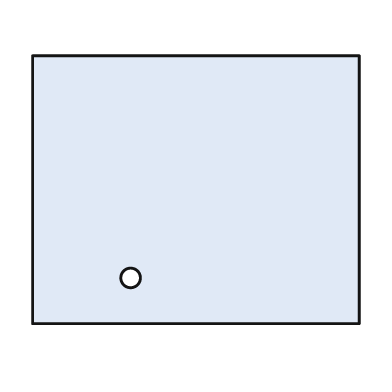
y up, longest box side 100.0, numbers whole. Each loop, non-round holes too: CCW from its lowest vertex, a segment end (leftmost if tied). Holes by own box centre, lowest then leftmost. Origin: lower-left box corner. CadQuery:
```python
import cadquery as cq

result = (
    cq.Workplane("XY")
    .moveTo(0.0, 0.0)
    .lineTo(100.0, 0.0)
    .lineTo(100.0, 82.0)
    .lineTo(0.0, 82.0)
    .close()
    .moveTo(30.0, 14.0)
    .circle(3.0)
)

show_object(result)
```